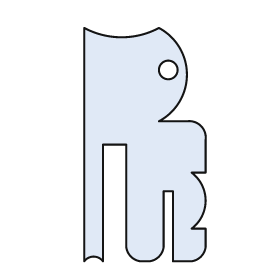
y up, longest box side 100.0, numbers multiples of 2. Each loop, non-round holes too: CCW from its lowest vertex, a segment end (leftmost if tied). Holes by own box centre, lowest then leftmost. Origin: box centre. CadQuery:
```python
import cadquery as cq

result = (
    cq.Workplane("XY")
    .moveTo(-26.0, -50.0)
    .threePointArc((-22.0, -48.0), (-18.0, -50.0))
    .lineTo(-18.0, 0.0)
    .lineTo(-8.0, 0.0)
    .lineTo(-8.0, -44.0)
    .threePointArc((-6.0, -48.0), (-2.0, -50.0))
    .lineTo(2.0, -50.0)
    .threePointArc((6.0, -48.0), (8.0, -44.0))
    .lineTo(8.0, -20.0)
    .lineTo(12.0, -20.0)
    .lineTo(12.0, -50.0)
    .lineTo(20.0, -50.0)
    .threePointArc((24.0, -48.0), (26.0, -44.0))
    .lineTo(26.0, -36.0)
    .lineTo(20.0, -36.0)
    .threePointArc((26.0, -24.0), (20.0, -12.0))
    .lineTo(26.0, -12.0)
    .lineTo(26.0, 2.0)
    .threePointArc((24.0, 8.0), (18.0, 10.0))
    .lineTo(6.0, 10.0)
    .threePointArc((18.0, 30.0), (6.0, 50.0))
    .threePointArc((-10.0, 46.0), (-26.0, 50.0))
    .close()
    .moveTo(10.0, 32.0)
    .circle(4.0)
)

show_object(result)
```